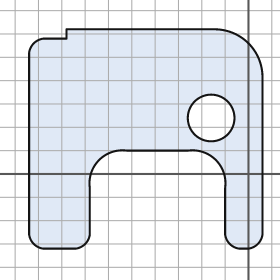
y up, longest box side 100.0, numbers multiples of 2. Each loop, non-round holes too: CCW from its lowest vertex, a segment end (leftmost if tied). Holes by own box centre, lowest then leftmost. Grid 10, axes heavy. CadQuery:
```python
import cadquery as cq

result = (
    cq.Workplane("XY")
    .moveTo(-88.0, -32.0)
    .lineTo(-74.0, -32.0)
    .threePointArc((-70.0, -30.0), (-68.0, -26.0))
    .lineTo(-68.0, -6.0)
    .threePointArc((-64.0, 6.0), (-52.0, 10.0))
    .lineTo(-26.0, 10.0)
    .threePointArc((-14.0, 6.0), (-10.0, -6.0))
    .lineTo(-10.0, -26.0)
    .threePointArc((-8.0, -30.0), (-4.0, -32.0))
    .lineTo(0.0, -32.0)
    .threePointArc((4.0, -30.0), (6.0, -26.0))
    .lineTo(6.0, 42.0)
    .threePointArc((0.0, 56.0), (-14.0, 62.0))
    .lineTo(-78.0, 62.0)
    .lineTo(-78.0, 58.0)
    .lineTo(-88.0, 58.0)
    .threePointArc((-92.0, 56.0), (-94.0, 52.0))
    .lineTo(-94.0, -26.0)
    .threePointArc((-92.0, -30.0), (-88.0, -32.0))
    .close()
    .moveTo(-16.0, 24.0)
    .circle(10.0)
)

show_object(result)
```